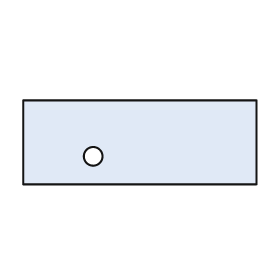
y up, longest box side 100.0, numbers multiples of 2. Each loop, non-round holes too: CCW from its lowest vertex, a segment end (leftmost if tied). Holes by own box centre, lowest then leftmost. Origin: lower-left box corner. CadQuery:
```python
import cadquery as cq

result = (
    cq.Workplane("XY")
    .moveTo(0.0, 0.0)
    .lineTo(100.0, 0.0)
    .lineTo(100.0, 36.0)
    .lineTo(0.0, 36.0)
    .close()
    .moveTo(30.0, 12.0)
    .circle(4.0)
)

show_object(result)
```